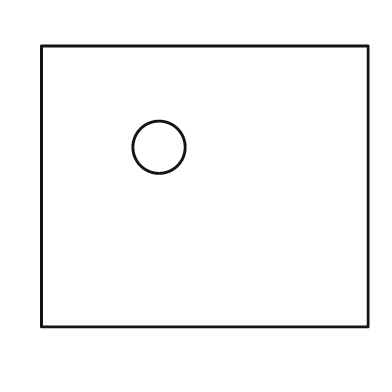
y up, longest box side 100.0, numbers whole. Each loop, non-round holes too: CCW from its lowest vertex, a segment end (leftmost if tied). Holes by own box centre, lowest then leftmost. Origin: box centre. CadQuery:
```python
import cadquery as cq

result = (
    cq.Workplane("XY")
    .moveTo(-50.0, -43.0)
    .lineTo(50.0, -43.0)
    .lineTo(50.0, 43.0)
    .lineTo(-50.0, 43.0)
    .close()
    .moveTo(-14.0, 12.0)
    .circle(8.0)
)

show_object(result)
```